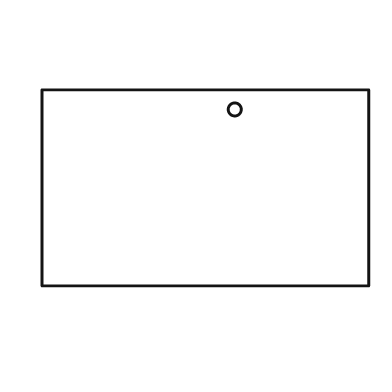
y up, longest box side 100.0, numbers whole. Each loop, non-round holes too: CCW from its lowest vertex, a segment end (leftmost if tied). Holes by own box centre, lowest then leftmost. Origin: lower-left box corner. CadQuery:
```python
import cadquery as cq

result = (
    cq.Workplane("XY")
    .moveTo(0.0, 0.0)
    .lineTo(100.0, 0.0)
    .lineTo(100.0, 60.0)
    .lineTo(0.0, 60.0)
    .close()
    .moveTo(59.0, 54.0)
    .circle(2.0)
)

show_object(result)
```